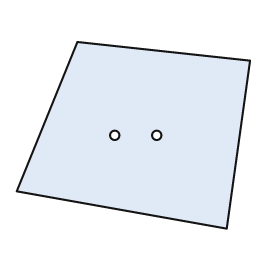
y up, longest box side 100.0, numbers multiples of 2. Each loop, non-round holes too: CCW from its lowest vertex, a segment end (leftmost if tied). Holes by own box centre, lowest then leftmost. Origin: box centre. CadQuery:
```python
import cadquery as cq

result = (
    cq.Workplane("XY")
    .moveTo(40.0, -40.0)
    .lineTo(50.0, 32.0)
    .lineTo(-24.0, 40.0)
    .lineTo(-50.0, -24.0)
    .close()
    .moveTo(-8.0, 0.0)
    .circle(2.0)
    .moveTo(10.0, 0.0)
    .circle(2.0)
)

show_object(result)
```